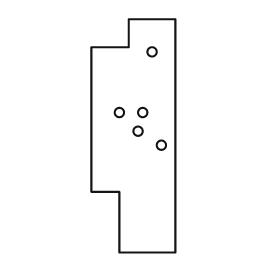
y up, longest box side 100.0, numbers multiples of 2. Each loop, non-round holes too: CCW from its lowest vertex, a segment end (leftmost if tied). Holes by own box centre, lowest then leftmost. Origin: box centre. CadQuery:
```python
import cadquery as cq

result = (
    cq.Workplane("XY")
    .moveTo(-6.0, -50.0)
    .lineTo(18.0, -50.0)
    .lineTo(18.0, 50.0)
    .lineTo(-2.0, 50.0)
    .lineTo(-2.0, 38.0)
    .lineTo(-18.0, 38.0)
    .lineTo(-18.0, -24.0)
    .lineTo(-6.0, -24.0)
    .close()
    .moveTo(12.0, -4.0)
    .circle(2.0)
    .moveTo(2.0, 2.0)
    .circle(2.0)
    .moveTo(-6.0, 10.0)
    .circle(2.0)
    .moveTo(4.0, 10.0)
    .circle(2.0)
    .moveTo(8.0, 36.0)
    .circle(2.0)
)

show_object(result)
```